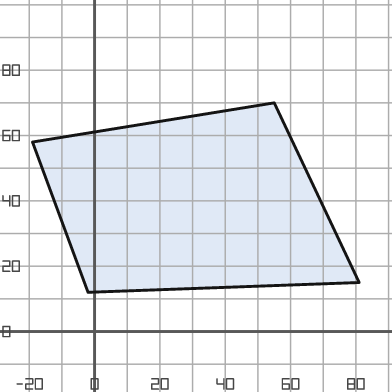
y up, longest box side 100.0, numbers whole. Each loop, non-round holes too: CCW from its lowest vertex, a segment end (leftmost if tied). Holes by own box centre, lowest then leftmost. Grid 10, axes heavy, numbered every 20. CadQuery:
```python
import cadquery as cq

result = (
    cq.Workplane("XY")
    .moveTo(-2.0, 12.0)
    .lineTo(81.0, 15.0)
    .lineTo(55.0, 70.0)
    .lineTo(-19.0, 58.0)
    .close()
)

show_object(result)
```